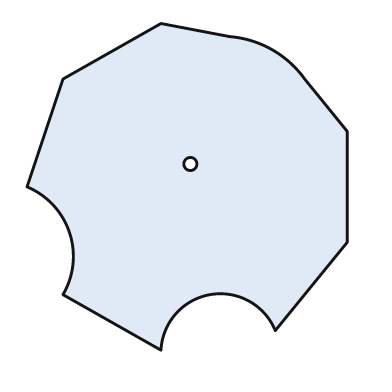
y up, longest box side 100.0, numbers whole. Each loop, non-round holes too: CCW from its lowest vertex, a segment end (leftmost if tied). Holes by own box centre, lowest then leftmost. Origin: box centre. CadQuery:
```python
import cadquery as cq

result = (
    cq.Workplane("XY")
    .moveTo(-8.0, -50.0)
    .threePointArc((7.0, -33.0), (27.0, -44.0))
    .lineTo(49.0, -17.0)
    .lineTo(49.0, 17.0)
    .lineTo(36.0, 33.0)
    .threePointArc((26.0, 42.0), (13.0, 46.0))
    .lineTo(-8.0, 50.0)
    .lineTo(-38.0, 33.0)
    .lineTo(-49.0, 0.0)
    .threePointArc((-36.0, -14.0), (-38.0, -33.0))
    .close()
    .moveTo(1.0, 7.0)
    .circle(2.0)
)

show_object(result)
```